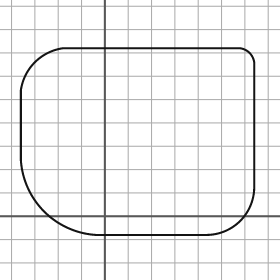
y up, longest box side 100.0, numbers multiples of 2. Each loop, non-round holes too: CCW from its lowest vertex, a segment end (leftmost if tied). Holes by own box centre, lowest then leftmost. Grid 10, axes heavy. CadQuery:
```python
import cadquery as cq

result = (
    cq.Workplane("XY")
    .moveTo(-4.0, -8.0)
    .lineTo(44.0, -8.0)
    .threePointArc((58.0, -2.0), (64.0, 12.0))
    .lineTo(64.0, 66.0)
    .threePointArc((62.0, 70.0), (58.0, 72.0))
    .lineTo(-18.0, 72.0)
    .threePointArc((-30.0, 66.0), (-36.0, 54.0))
    .lineTo(-36.0, 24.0)
    .threePointArc((-26.0, 2.0), (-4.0, -8.0))
    .close()
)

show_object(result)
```